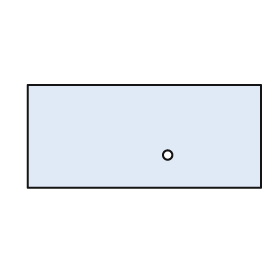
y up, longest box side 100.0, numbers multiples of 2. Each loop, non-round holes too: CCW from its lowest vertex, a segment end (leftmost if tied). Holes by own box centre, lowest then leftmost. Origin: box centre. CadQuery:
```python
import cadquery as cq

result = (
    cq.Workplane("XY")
    .moveTo(-50.0, -22.0)
    .lineTo(50.0, -22.0)
    .lineTo(50.0, 22.0)
    .lineTo(-50.0, 22.0)
    .close()
    .moveTo(10.0, -8.0)
    .circle(2.0)
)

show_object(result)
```